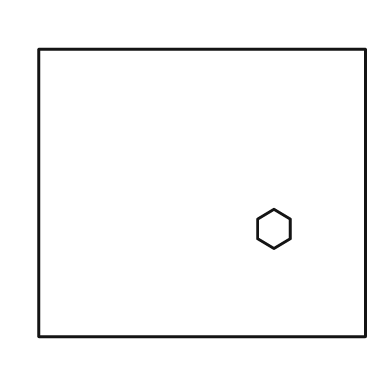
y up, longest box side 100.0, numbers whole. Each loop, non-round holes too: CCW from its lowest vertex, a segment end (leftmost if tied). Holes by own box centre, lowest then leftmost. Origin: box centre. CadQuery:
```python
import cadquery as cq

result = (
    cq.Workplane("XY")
    .moveTo(-50.0, -44.0)
    .lineTo(50.0, -44.0)
    .lineTo(50.0, 44.0)
    .lineTo(-50.0, 44.0)
    .close()
    .moveTo(22.0, -17.0)
    .lineTo(27.0, -14.0)
    .lineTo(27.0, -8.0)
    .lineTo(22.0, -5.0)
    .lineTo(17.0, -8.0)
    .lineTo(17.0, -14.0)
    .close()
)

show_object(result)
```